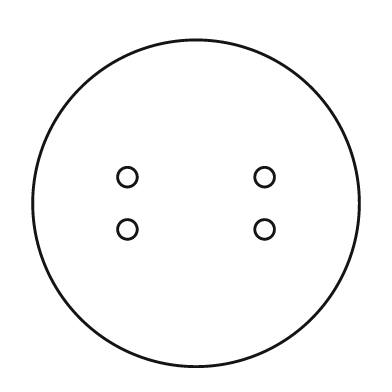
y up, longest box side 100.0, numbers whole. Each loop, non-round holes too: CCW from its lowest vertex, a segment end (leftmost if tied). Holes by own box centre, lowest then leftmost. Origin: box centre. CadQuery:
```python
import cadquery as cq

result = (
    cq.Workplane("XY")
    .moveTo(0.0, 0.0)
    .circle(50.0)
    .moveTo(-21.0, -8.0)
    .circle(3.0)
    .moveTo(21.0, -8.0)
    .circle(3.0)
    .moveTo(-21.0, 8.0)
    .circle(3.0)
    .moveTo(21.0, 8.0)
    .circle(3.0)
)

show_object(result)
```